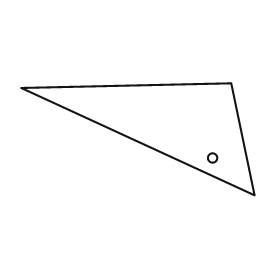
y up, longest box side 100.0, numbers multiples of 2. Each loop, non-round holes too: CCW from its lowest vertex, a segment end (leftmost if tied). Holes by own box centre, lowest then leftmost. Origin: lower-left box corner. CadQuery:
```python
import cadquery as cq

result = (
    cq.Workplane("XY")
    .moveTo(100.0, 0.0)
    .lineTo(90.0, 48.0)
    .lineTo(0.0, 46.0)
    .close()
    .moveTo(82.0, 16.0)
    .circle(2.0)
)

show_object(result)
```